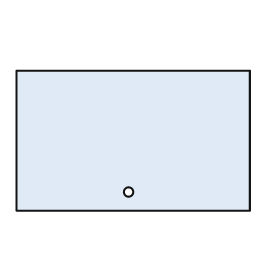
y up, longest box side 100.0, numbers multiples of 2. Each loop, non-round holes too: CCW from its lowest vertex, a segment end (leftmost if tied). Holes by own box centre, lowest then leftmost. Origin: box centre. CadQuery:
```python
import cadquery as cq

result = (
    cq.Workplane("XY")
    .moveTo(-50.0, -30.0)
    .lineTo(50.0, -30.0)
    .lineTo(50.0, 30.0)
    .lineTo(-50.0, 30.0)
    .close()
    .moveTo(-2.0, -22.0)
    .circle(2.0)
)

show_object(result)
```